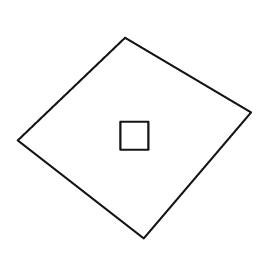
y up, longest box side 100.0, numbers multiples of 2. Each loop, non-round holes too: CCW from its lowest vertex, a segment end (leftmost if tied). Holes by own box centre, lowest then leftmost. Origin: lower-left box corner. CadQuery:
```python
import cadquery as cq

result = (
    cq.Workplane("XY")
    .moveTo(54.0, 0.0)
    .lineTo(100.0, 54.0)
    .lineTo(46.0, 86.0)
    .lineTo(0.0, 42.0)
    .close()
    .moveTo(44.0, 38.0)
    .lineTo(56.0, 38.0)
    .lineTo(56.0, 50.0)
    .lineTo(44.0, 50.0)
    .close()
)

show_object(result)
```